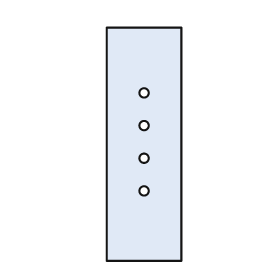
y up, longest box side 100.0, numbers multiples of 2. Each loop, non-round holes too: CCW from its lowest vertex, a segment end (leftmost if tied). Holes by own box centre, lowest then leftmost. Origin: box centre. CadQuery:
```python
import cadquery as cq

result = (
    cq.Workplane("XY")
    .moveTo(-16.0, -50.0)
    .lineTo(16.0, -50.0)
    .lineTo(16.0, 50.0)
    .lineTo(-16.0, 50.0)
    .close()
    .moveTo(0.0, -20.0)
    .circle(2.0)
    .moveTo(0.0, -6.0)
    .circle(2.0)
    .moveTo(0.0, 8.0)
    .circle(2.0)
    .moveTo(0.0, 22.0)
    .circle(2.0)
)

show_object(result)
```